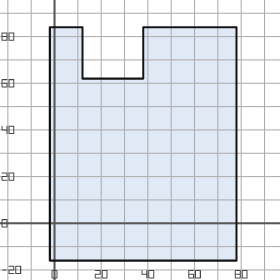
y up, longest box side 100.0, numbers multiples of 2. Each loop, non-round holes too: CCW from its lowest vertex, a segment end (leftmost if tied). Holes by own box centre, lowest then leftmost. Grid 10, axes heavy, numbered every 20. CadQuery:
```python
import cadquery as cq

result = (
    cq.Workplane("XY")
    .moveTo(-2.0, -16.0)
    .lineTo(78.0, -16.0)
    .lineTo(78.0, 84.0)
    .lineTo(38.0, 84.0)
    .lineTo(38.0, 62.0)
    .lineTo(12.0, 62.0)
    .lineTo(12.0, 84.0)
    .lineTo(-2.0, 84.0)
    .close()
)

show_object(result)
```